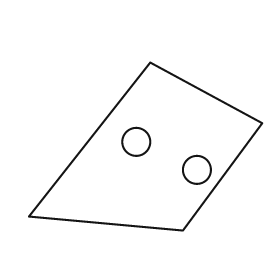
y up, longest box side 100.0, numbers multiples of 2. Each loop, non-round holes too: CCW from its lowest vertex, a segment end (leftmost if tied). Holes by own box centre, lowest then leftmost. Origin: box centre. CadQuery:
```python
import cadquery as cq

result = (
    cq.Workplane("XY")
    .moveTo(16.0, -36.0)
    .lineTo(50.0, 10.0)
    .lineTo(2.0, 36.0)
    .lineTo(-50.0, -30.0)
    .close()
    .moveTo(22.0, -10.0)
    .circle(6.0)
    .moveTo(-4.0, 2.0)
    .circle(6.0)
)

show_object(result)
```